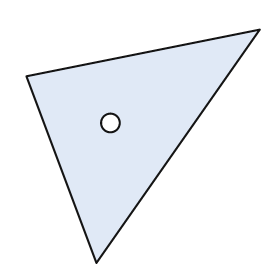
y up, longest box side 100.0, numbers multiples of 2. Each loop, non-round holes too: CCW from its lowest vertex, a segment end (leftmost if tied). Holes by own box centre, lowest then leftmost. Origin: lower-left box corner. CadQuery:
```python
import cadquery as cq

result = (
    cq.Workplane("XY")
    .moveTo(30.0, 0.0)
    .lineTo(100.0, 100.0)
    .lineTo(0.0, 80.0)
    .close()
    .moveTo(36.0, 60.0)
    .circle(4.0)
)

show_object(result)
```